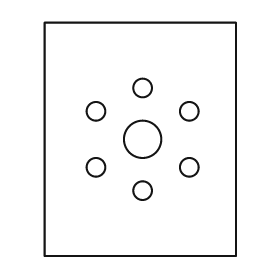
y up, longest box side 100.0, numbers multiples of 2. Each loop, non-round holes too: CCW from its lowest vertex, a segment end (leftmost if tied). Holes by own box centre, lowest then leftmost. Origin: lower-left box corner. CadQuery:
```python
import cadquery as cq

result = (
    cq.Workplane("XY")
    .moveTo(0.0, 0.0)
    .lineTo(82.0, 0.0)
    .lineTo(82.0, 100.0)
    .lineTo(0.0, 100.0)
    .close()
    .moveTo(42.0, 28.0)
    .circle(4.0)
    .moveTo(22.0, 38.0)
    .circle(4.0)
    .moveTo(62.0, 38.0)
    .circle(4.0)
    .moveTo(42.0, 50.0)
    .circle(8.0)
    .moveTo(22.0, 62.0)
    .circle(4.0)
    .moveTo(62.0, 62.0)
    .circle(4.0)
    .moveTo(42.0, 72.0)
    .circle(4.0)
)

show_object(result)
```